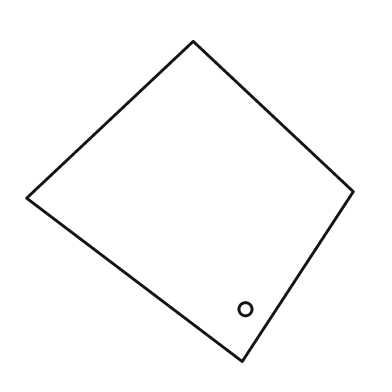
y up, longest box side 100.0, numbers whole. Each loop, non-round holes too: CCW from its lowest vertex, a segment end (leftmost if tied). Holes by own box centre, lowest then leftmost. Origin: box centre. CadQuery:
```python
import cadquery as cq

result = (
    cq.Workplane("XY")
    .moveTo(16.0, -49.0)
    .lineTo(50.0, 3.0)
    .lineTo(1.0, 49.0)
    .lineTo(-50.0, 1.0)
    .close()
    .moveTo(17.0, -33.0)
    .circle(2.0)
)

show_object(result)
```